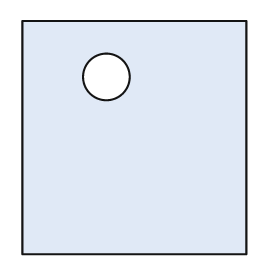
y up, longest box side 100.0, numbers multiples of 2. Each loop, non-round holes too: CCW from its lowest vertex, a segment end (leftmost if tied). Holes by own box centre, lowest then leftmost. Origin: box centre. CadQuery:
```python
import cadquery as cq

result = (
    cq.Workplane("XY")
    .moveTo(-48.0, -50.0)
    .lineTo(48.0, -50.0)
    .lineTo(48.0, 50.0)
    .lineTo(-48.0, 50.0)
    .close()
    .moveTo(-12.0, 26.0)
    .circle(10.0)
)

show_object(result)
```